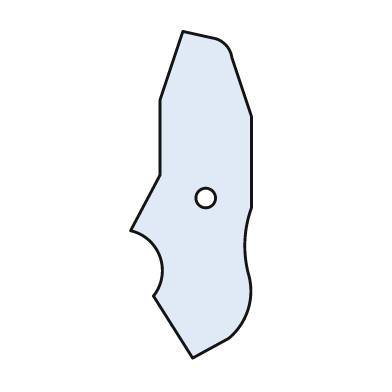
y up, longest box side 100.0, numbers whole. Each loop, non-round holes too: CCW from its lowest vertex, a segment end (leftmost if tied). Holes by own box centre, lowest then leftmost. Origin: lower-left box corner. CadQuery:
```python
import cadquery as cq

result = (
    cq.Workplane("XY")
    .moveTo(19.0, 0.0)
    .lineTo(30.0, 6.0)
    .threePointArc((36.0, 15.0), (36.0, 26.0))
    .threePointArc((35.0, 36.0), (37.0, 46.0))
    .lineTo(37.0, 74.0)
    .lineTo(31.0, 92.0)
    .threePointArc((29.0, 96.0), (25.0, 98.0))
    .lineTo(16.0, 100.0)
    .lineTo(9.0, 79.0)
    .lineTo(9.0, 56.0)
    .lineTo(0.0, 39.0)
    .threePointArc((9.0, 31.0), (7.0, 19.0))
    .close()
    .moveTo(23.0, 49.0)
    .circle(3.0)
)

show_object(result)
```